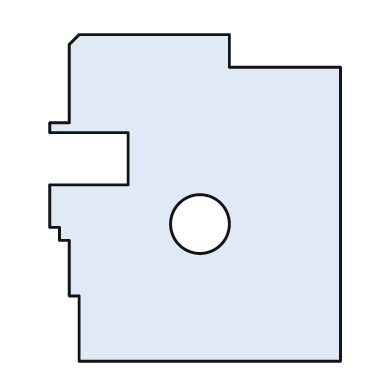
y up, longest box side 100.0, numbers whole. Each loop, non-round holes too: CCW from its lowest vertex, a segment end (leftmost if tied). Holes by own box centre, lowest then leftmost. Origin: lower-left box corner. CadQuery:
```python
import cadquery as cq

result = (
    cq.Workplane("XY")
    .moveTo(9.0, 0.0)
    .lineTo(89.0, 0.0)
    .lineTo(89.0, 90.0)
    .lineTo(55.0, 90.0)
    .lineTo(55.0, 100.0)
    .lineTo(9.0, 100.0)
    .lineTo(6.0, 97.0)
    .lineTo(6.0, 73.0)
    .lineTo(0.0, 73.0)
    .lineTo(0.0, 70.0)
    .lineTo(24.0, 70.0)
    .lineTo(24.0, 54.0)
    .lineTo(0.0, 54.0)
    .lineTo(0.0, 41.0)
    .lineTo(3.0, 41.0)
    .lineTo(3.0, 37.0)
    .lineTo(6.0, 37.0)
    .lineTo(6.0, 20.0)
    .lineTo(9.0, 20.0)
    .close()
    .moveTo(46.0, 42.0)
    .circle(9.0)
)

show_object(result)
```